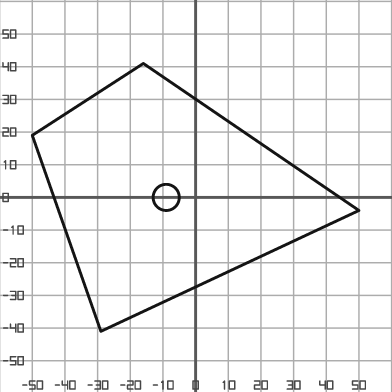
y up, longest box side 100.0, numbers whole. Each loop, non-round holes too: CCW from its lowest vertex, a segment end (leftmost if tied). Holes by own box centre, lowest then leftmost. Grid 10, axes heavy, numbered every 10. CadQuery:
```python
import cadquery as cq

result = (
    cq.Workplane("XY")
    .moveTo(-29.0, -41.0)
    .lineTo(50.0, -4.0)
    .lineTo(-16.0, 41.0)
    .lineTo(-50.0, 19.0)
    .close()
    .moveTo(-9.0, 0.0)
    .circle(4.0)
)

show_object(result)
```